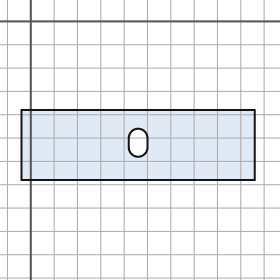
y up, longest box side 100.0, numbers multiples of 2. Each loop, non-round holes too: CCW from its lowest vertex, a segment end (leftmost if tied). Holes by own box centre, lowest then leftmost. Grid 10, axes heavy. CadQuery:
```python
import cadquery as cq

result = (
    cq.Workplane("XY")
    .moveTo(-4.0, -68.0)
    .lineTo(96.0, -68.0)
    .lineTo(96.0, -38.0)
    .lineTo(-4.0, -38.0)
    .close()
    .moveTo(42.0, -54.0)
    .threePointArc((46.0, -58.0), (50.0, -54.0))
    .lineTo(50.0, -50.0)
    .threePointArc((46.0, -46.0), (42.0, -50.0))
    .close()
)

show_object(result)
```